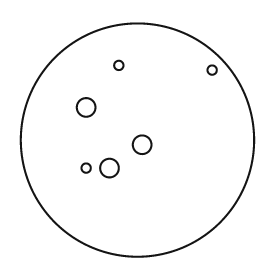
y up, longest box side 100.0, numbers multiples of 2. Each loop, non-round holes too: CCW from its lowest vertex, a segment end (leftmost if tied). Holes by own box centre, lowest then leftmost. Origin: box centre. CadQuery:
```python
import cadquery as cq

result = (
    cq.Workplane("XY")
    .moveTo(0.0, 0.0)
    .circle(50.0)
    .moveTo(-22.0, -12.0)
    .circle(2.0)
    .moveTo(-12.0, -12.0)
    .circle(4.0)
    .moveTo(2.0, -2.0)
    .circle(4.0)
    .moveTo(-22.0, 14.0)
    .circle(4.0)
    .moveTo(32.0, 30.0)
    .circle(2.0)
    .moveTo(-8.0, 32.0)
    .circle(2.0)
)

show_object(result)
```